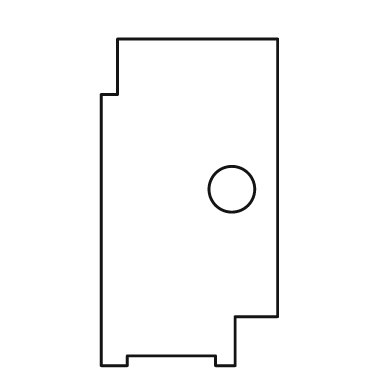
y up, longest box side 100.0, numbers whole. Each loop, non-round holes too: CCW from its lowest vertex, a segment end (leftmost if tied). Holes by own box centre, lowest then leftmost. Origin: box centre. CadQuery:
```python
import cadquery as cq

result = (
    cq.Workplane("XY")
    .moveTo(-27.0, -50.0)
    .lineTo(-19.0, -50.0)
    .lineTo(-19.0, -47.0)
    .lineTo(8.0, -47.0)
    .lineTo(8.0, -50.0)
    .lineTo(14.0, -50.0)
    .lineTo(14.0, -35.0)
    .lineTo(27.0, -35.0)
    .lineTo(27.0, 50.0)
    .lineTo(-22.0, 50.0)
    .lineTo(-22.0, 33.0)
    .lineTo(-27.0, 33.0)
    .close()
    .moveTo(13.0, 4.0)
    .circle(7.0)
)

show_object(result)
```